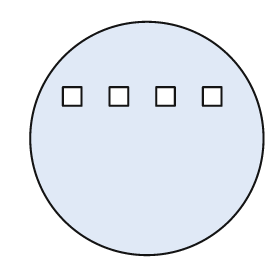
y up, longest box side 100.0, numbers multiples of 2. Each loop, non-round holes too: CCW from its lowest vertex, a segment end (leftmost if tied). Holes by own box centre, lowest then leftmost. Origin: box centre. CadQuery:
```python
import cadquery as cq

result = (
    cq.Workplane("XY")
    .moveTo(0.0, 0.0)
    .circle(50.0)
    .moveTo(-36.0, 14.0)
    .lineTo(-28.0, 14.0)
    .lineTo(-28.0, 22.0)
    .lineTo(-36.0, 22.0)
    .close()
    .moveTo(-16.0, 14.0)
    .lineTo(-8.0, 14.0)
    .lineTo(-8.0, 22.0)
    .lineTo(-16.0, 22.0)
    .close()
    .moveTo(4.0, 14.0)
    .lineTo(12.0, 14.0)
    .lineTo(12.0, 22.0)
    .lineTo(4.0, 22.0)
    .close()
    .moveTo(24.0, 14.0)
    .lineTo(32.0, 14.0)
    .lineTo(32.0, 22.0)
    .lineTo(24.0, 22.0)
    .close()
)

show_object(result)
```